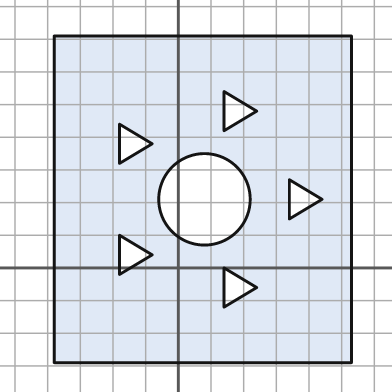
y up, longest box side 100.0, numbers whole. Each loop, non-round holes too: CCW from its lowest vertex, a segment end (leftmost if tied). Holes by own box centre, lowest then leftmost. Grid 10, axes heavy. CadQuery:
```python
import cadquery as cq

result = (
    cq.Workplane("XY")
    .moveTo(-38.0, -29.0)
    .lineTo(53.0, -29.0)
    .lineTo(53.0, 71.0)
    .lineTo(-38.0, 71.0)
    .close()
    .moveTo(14.0, -12.0)
    .lineTo(24.0, -6.0)
    .lineTo(14.0, 0.0)
    .close()
    .moveTo(-18.0, -2.0)
    .lineTo(-8.0, 4.0)
    .lineTo(-18.0, 10.0)
    .close()
    .moveTo(8.0, 21.0)
    .circle(14.0)
    .moveTo(34.0, 15.0)
    .lineTo(44.0, 21.0)
    .lineTo(34.0, 27.0)
    .close()
    .moveTo(-18.0, 32.0)
    .lineTo(-8.0, 38.0)
    .lineTo(-18.0, 44.0)
    .close()
    .moveTo(14.0, 42.0)
    .lineTo(24.0, 48.0)
    .lineTo(14.0, 54.0)
    .close()
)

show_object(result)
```